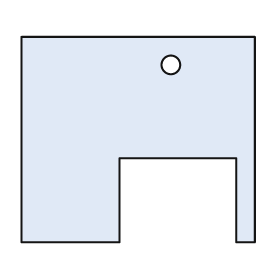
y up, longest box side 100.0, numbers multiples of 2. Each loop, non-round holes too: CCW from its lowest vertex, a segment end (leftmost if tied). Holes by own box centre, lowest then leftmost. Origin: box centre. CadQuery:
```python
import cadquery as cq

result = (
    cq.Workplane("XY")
    .moveTo(-50.0, -44.0)
    .lineTo(-8.0, -44.0)
    .lineTo(-8.0, -8.0)
    .lineTo(42.0, -8.0)
    .lineTo(42.0, -44.0)
    .lineTo(50.0, -44.0)
    .lineTo(50.0, 44.0)
    .lineTo(-50.0, 44.0)
    .close()
    .moveTo(14.0, 32.0)
    .circle(4.0)
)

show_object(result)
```